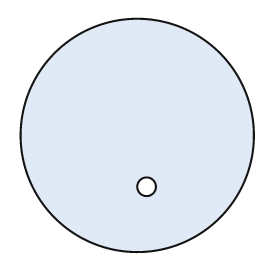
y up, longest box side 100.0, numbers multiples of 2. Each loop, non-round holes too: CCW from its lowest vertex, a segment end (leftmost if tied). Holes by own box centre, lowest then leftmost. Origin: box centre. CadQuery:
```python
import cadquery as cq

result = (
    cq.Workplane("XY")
    .moveTo(0.0, 0.0)
    .circle(50.0)
    .moveTo(4.0, -22.0)
    .circle(4.0)
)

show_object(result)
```